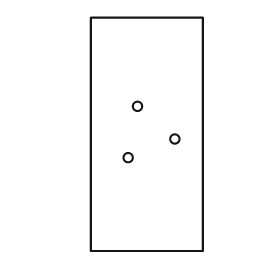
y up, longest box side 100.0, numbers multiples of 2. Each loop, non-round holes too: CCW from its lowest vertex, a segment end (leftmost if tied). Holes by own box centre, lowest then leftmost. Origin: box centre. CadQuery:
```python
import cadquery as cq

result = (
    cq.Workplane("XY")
    .moveTo(-24.0, -50.0)
    .lineTo(24.0, -50.0)
    .lineTo(24.0, 50.0)
    .lineTo(-24.0, 50.0)
    .close()
    .moveTo(-8.0, -10.0)
    .circle(2.0)
    .moveTo(12.0, -2.0)
    .circle(2.0)
    .moveTo(-4.0, 12.0)
    .circle(2.0)
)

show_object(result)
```